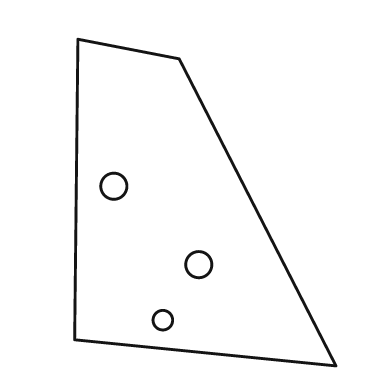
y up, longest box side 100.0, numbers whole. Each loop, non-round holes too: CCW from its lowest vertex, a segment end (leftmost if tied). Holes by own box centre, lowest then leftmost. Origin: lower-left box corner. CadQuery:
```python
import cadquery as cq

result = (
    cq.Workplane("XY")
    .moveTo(80.0, 0.0)
    .lineTo(32.0, 94.0)
    .lineTo(1.0, 100.0)
    .lineTo(0.0, 8.0)
    .close()
    .moveTo(27.0, 14.0)
    .circle(3.0)
    .moveTo(38.0, 31.0)
    .circle(4.0)
    .moveTo(12.0, 55.0)
    .circle(4.0)
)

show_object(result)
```